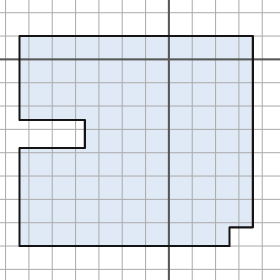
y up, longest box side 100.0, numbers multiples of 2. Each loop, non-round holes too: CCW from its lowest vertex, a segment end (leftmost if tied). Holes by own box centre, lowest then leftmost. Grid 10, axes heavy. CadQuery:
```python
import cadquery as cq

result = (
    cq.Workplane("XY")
    .moveTo(-64.0, -80.0)
    .lineTo(26.0, -80.0)
    .lineTo(26.0, -72.0)
    .lineTo(36.0, -72.0)
    .lineTo(36.0, 10.0)
    .lineTo(-64.0, 10.0)
    .lineTo(-64.0, -26.0)
    .lineTo(-36.0, -26.0)
    .lineTo(-36.0, -38.0)
    .lineTo(-64.0, -38.0)
    .close()
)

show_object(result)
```